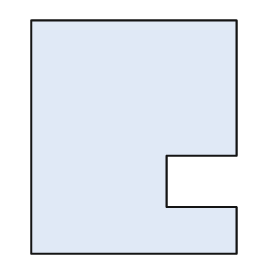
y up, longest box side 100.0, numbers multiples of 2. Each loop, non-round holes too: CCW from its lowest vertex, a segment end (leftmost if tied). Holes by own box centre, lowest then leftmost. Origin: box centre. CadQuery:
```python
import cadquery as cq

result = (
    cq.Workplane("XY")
    .moveTo(-44.0, -50.0)
    .lineTo(44.0, -50.0)
    .lineTo(44.0, -30.0)
    .lineTo(14.0, -30.0)
    .lineTo(14.0, -8.0)
    .lineTo(44.0, -8.0)
    .lineTo(44.0, 50.0)
    .lineTo(-44.0, 50.0)
    .close()
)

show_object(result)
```